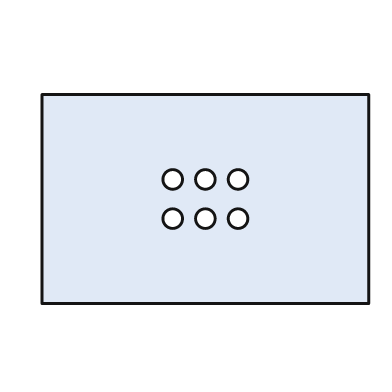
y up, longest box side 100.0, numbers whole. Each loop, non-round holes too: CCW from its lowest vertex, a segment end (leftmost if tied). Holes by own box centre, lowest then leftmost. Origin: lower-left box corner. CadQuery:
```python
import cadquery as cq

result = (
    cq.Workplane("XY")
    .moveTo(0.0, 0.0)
    .lineTo(100.0, 0.0)
    .lineTo(100.0, 64.0)
    .lineTo(0.0, 64.0)
    .close()
    .moveTo(40.0, 26.0)
    .circle(3.0)
    .moveTo(50.0, 26.0)
    .circle(3.0)
    .moveTo(60.0, 26.0)
    .circle(3.0)
    .moveTo(40.0, 38.0)
    .circle(3.0)
    .moveTo(50.0, 38.0)
    .circle(3.0)
    .moveTo(60.0, 38.0)
    .circle(3.0)
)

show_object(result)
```